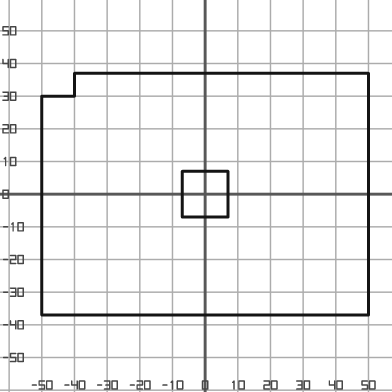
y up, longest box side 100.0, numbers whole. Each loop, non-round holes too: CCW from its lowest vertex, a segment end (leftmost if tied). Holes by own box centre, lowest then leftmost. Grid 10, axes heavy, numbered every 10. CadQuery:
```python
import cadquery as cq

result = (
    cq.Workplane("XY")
    .moveTo(-50.0, -37.0)
    .lineTo(50.0, -37.0)
    .lineTo(50.0, 37.0)
    .lineTo(-40.0, 37.0)
    .lineTo(-40.0, 30.0)
    .lineTo(-50.0, 30.0)
    .close()
    .moveTo(-7.0, -7.0)
    .lineTo(7.0, -7.0)
    .lineTo(7.0, 7.0)
    .lineTo(-7.0, 7.0)
    .close()
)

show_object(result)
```